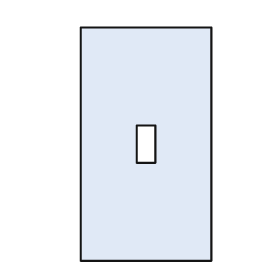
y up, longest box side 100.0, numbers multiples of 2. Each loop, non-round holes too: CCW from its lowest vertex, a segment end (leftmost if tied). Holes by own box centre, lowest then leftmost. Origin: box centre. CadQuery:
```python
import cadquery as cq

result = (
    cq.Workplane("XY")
    .moveTo(-28.0, -50.0)
    .lineTo(28.0, -50.0)
    .lineTo(28.0, 50.0)
    .lineTo(-28.0, 50.0)
    .close()
    .moveTo(-4.0, -8.0)
    .lineTo(4.0, -8.0)
    .lineTo(4.0, 8.0)
    .lineTo(-4.0, 8.0)
    .close()
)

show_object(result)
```